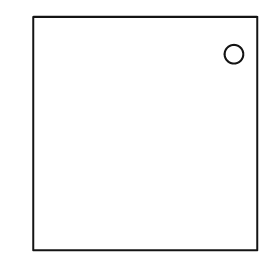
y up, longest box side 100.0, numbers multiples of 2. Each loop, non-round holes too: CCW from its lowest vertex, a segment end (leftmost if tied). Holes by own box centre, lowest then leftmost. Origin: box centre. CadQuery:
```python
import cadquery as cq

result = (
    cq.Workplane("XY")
    .moveTo(-48.0, -50.0)
    .lineTo(48.0, -50.0)
    .lineTo(48.0, 50.0)
    .lineTo(-48.0, 50.0)
    .close()
    .moveTo(38.0, 34.0)
    .circle(4.0)
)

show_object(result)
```